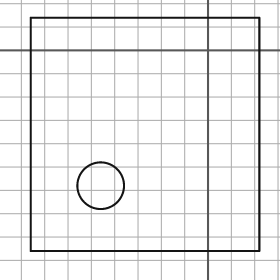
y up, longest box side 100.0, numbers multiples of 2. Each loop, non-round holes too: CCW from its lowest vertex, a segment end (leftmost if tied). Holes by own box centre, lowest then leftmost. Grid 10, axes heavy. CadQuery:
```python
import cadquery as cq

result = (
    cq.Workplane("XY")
    .moveTo(-76.0, -86.0)
    .lineTo(22.0, -86.0)
    .lineTo(22.0, 14.0)
    .lineTo(-76.0, 14.0)
    .close()
    .moveTo(-46.0, -58.0)
    .circle(10.0)
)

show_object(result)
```